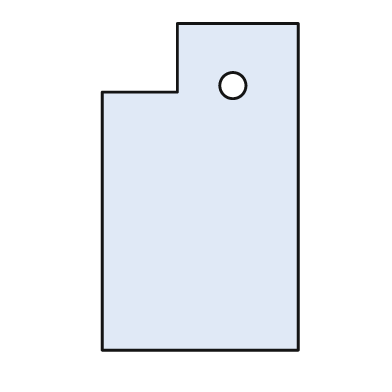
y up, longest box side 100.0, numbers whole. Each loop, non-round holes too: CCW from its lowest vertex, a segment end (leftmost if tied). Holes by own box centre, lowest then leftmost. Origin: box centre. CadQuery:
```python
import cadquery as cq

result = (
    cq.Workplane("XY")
    .moveTo(-30.0, -50.0)
    .lineTo(30.0, -50.0)
    .lineTo(30.0, 50.0)
    .lineTo(-7.0, 50.0)
    .lineTo(-7.0, 29.0)
    .lineTo(-30.0, 29.0)
    .close()
    .moveTo(10.0, 31.0)
    .circle(4.0)
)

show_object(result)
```